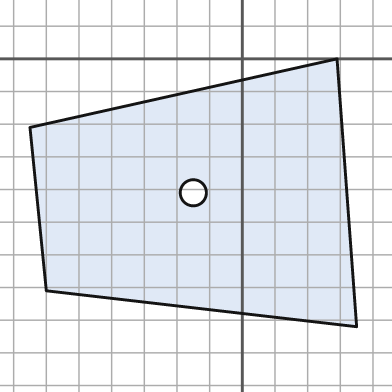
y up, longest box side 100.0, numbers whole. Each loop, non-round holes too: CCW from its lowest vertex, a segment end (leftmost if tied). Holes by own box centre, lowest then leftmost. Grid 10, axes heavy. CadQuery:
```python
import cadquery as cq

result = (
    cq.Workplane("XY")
    .moveTo(35.0, -82.0)
    .lineTo(29.0, 0.0)
    .lineTo(-65.0, -21.0)
    .lineTo(-60.0, -71.0)
    .close()
    .moveTo(-15.0, -41.0)
    .circle(4.0)
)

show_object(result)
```